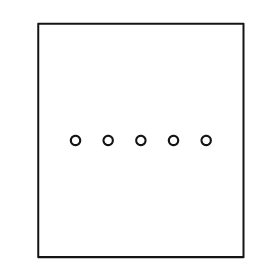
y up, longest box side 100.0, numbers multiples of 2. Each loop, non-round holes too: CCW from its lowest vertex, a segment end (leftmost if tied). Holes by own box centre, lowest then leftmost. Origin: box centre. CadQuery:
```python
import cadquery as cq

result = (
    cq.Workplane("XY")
    .moveTo(-44.0, -50.0)
    .lineTo(44.0, -50.0)
    .lineTo(44.0, 50.0)
    .lineTo(-44.0, 50.0)
    .close()
    .moveTo(-28.0, 0.0)
    .circle(2.0)
    .moveTo(-14.0, 0.0)
    .circle(2.0)
    .moveTo(0.0, 0.0)
    .circle(2.0)
    .moveTo(14.0, 0.0)
    .circle(2.0)
    .moveTo(28.0, 0.0)
    .circle(2.0)
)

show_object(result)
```